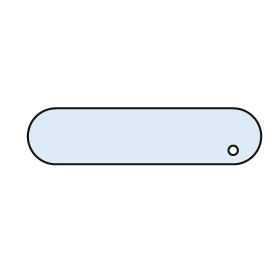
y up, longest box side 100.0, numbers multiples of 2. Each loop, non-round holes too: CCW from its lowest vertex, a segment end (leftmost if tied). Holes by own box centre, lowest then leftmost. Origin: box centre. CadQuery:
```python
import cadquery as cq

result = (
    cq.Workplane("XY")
    .moveTo(-38.0, -12.0)
    .lineTo(38.0, -12.0)
    .threePointArc((50.0, 0.0), (38.0, 12.0))
    .lineTo(-38.0, 12.0)
    .threePointArc((-50.0, 0.0), (-38.0, -12.0))
    .close()
    .moveTo(38.0, -6.0)
    .circle(2.0)
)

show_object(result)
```